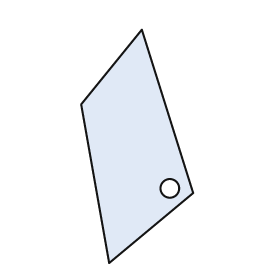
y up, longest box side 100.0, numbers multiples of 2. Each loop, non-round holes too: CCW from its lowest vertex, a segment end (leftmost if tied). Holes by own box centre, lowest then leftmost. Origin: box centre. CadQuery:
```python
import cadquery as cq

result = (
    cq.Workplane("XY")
    .moveTo(-12.0, -50.0)
    .lineTo(24.0, -20.0)
    .lineTo(2.0, 50.0)
    .lineTo(-24.0, 18.0)
    .close()
    .moveTo(14.0, -18.0)
    .circle(4.0)
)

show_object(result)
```